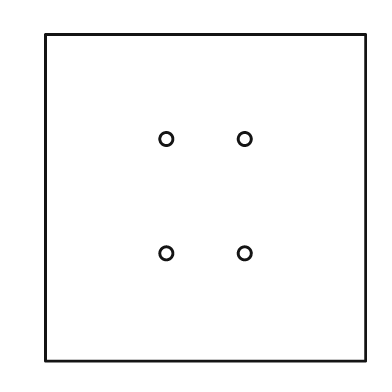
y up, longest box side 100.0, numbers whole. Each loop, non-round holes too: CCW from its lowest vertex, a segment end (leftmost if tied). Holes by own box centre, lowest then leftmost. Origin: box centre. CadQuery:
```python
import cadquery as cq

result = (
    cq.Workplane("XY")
    .moveTo(-49.0, -50.0)
    .lineTo(49.0, -50.0)
    .lineTo(49.0, 50.0)
    .lineTo(-49.0, 50.0)
    .close()
    .moveTo(-12.0, -17.0)
    .circle(2.0)
    .moveTo(12.0, -17.0)
    .circle(2.0)
    .moveTo(-12.0, 18.0)
    .circle(2.0)
    .moveTo(12.0, 18.0)
    .circle(2.0)
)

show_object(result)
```